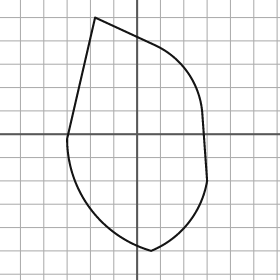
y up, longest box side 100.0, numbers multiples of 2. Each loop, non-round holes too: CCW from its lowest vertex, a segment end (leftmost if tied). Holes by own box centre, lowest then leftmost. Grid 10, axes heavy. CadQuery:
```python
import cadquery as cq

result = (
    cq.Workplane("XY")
    .moveTo(6.0, -50.0)
    .threePointArc((22.0, -38.0), (30.0, -20.0))
    .lineTo(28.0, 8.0)
    .threePointArc((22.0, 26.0), (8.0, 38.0))
    .lineTo(-18.0, 50.0)
    .lineTo(-30.0, -2.0)
    .threePointArc((-20.0, -32.0), (6.0, -50.0))
    .close()
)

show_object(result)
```